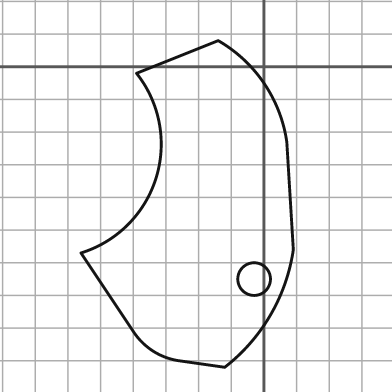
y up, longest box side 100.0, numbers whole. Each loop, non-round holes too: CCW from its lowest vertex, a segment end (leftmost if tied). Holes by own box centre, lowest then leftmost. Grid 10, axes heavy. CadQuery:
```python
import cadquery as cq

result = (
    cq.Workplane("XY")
    .moveTo(-12.0, -92.0)
    .threePointArc((2.0, -76.0), (9.0, -56.0))
    .lineTo(7.0, -23.0)
    .threePointArc((0.0, -5.0), (-14.0, 8.0))
    .lineTo(-39.0, -2.0)
    .threePointArc((-33.0, -34.0), (-56.0, -57.0))
    .lineTo(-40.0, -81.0)
    .threePointArc((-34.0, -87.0), (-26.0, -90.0))
    .close()
    .moveTo(-3.0, -65.0)
    .circle(5.0)
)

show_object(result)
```